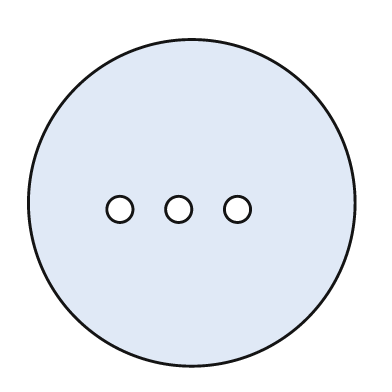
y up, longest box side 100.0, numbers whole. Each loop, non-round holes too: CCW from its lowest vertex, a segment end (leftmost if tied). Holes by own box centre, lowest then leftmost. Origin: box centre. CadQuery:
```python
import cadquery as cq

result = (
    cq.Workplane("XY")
    .moveTo(0.0, 0.0)
    .circle(50.0)
    .moveTo(-22.0, -2.0)
    .circle(4.0)
    .moveTo(-4.0, -2.0)
    .circle(4.0)
    .moveTo(14.0, -2.0)
    .circle(4.0)
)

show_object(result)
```